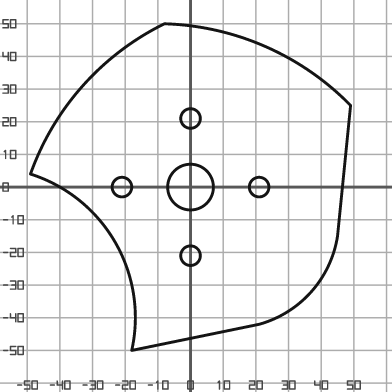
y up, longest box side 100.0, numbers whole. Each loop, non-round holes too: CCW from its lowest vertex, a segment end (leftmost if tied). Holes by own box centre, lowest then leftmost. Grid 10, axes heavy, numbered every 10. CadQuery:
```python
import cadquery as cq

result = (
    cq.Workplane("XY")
    .moveTo(-18.0, -50.0)
    .lineTo(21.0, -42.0)
    .threePointArc((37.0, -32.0), (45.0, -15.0))
    .lineTo(49.0, 25.0)
    .threePointArc((23.0, 43.0), (-8.0, 50.0))
    .threePointArc((-33.0, 31.0), (-49.0, 4.0))
    .threePointArc((-23.0, -17.0), (-18.0, -50.0))
    .close()
    .moveTo(0.0, -21.0)
    .circle(3.0)
    .moveTo(-21.0, 0.0)
    .circle(3.0)
    .moveTo(0.0, 0.0)
    .circle(7.0)
    .moveTo(21.0, 0.0)
    .circle(3.0)
    .moveTo(0.0, 21.0)
    .circle(3.0)
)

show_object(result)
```